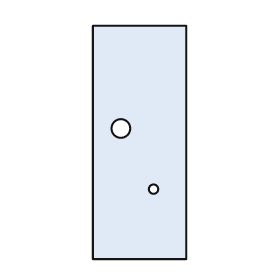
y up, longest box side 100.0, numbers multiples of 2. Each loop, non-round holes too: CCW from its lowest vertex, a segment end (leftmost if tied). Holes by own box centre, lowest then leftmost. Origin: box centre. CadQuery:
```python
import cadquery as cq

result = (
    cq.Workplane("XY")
    .moveTo(-20.0, -50.0)
    .lineTo(20.0, -50.0)
    .lineTo(20.0, 50.0)
    .lineTo(-20.0, 50.0)
    .close()
    .moveTo(6.0, -20.0)
    .circle(2.0)
    .moveTo(-8.0, 6.0)
    .circle(4.0)
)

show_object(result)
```